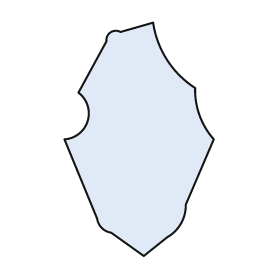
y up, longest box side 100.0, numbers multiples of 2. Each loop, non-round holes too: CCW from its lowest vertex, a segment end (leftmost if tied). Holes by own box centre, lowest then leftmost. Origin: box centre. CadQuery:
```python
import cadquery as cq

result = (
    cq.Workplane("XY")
    .moveTo(2.0, -50.0)
    .lineTo(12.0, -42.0)
    .threePointArc((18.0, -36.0), (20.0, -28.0))
    .lineTo(32.0, 0.0)
    .threePointArc((26.0, 10.0), (24.0, 22.0))
    .threePointArc((12.0, 34.0), (6.0, 50.0))
    .lineTo(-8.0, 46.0)
    .threePointArc((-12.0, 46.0), (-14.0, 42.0))
    .lineTo(-26.0, 20.0)
    .threePointArc((-22.0, 8.0), (-32.0, 0.0))
    .lineTo(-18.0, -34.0)
    .threePointArc((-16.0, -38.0), (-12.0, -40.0))
    .close()
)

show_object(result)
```